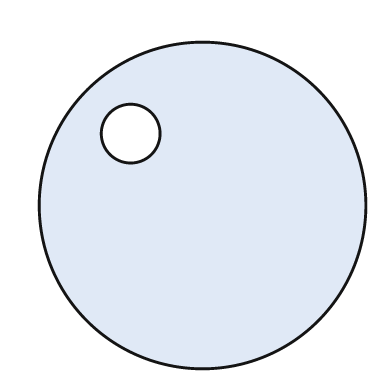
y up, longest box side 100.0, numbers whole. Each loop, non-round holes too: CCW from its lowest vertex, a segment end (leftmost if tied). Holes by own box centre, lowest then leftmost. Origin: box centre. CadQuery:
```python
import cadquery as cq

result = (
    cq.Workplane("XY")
    .moveTo(0.0, 0.0)
    .circle(50.0)
    .moveTo(-22.0, 22.0)
    .circle(9.0)
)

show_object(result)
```